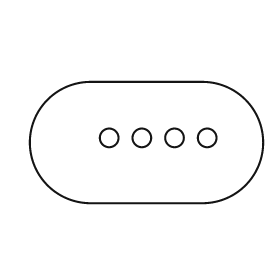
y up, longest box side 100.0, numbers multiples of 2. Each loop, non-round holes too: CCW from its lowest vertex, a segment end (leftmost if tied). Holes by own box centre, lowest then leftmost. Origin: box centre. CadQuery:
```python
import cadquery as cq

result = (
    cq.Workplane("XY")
    .moveTo(-24.0, -26.0)
    .lineTo(24.0, -26.0)
    .threePointArc((50.0, 0.0), (24.0, 26.0))
    .lineTo(-24.0, 26.0)
    .threePointArc((-50.0, 0.0), (-24.0, -26.0))
    .close()
    .moveTo(-16.0, 2.0)
    .circle(4.0)
    .moveTo(-2.0, 2.0)
    .circle(4.0)
    .moveTo(12.0, 2.0)
    .circle(4.0)
    .moveTo(26.0, 2.0)
    .circle(4.0)
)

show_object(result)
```